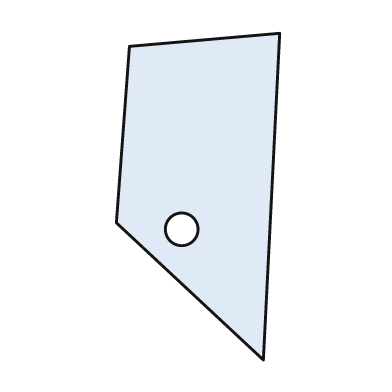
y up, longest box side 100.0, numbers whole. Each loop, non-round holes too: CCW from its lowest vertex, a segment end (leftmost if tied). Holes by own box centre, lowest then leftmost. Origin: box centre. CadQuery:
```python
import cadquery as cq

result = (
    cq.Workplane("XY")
    .moveTo(20.0, -50.0)
    .lineTo(25.0, 50.0)
    .lineTo(-21.0, 46.0)
    .lineTo(-25.0, -8.0)
    .close()
    .moveTo(-5.0, -10.0)
    .circle(5.0)
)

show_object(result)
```